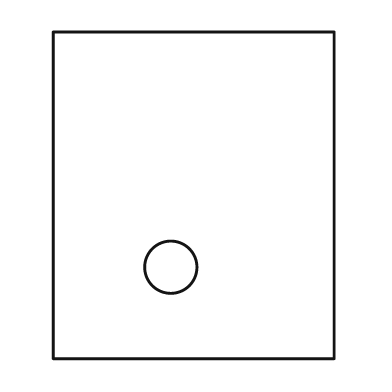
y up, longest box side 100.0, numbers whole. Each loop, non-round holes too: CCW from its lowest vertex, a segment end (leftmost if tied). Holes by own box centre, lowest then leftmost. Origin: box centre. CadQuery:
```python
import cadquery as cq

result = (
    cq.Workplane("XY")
    .moveTo(-43.0, -50.0)
    .lineTo(43.0, -50.0)
    .lineTo(43.0, 50.0)
    .lineTo(-43.0, 50.0)
    .close()
    .moveTo(-7.0, -22.0)
    .circle(8.0)
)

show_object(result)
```